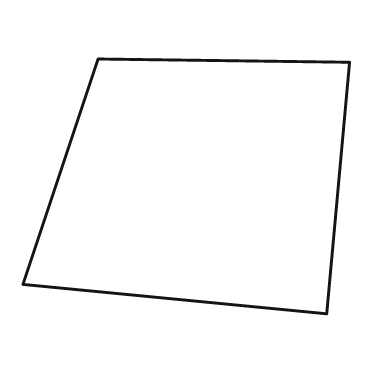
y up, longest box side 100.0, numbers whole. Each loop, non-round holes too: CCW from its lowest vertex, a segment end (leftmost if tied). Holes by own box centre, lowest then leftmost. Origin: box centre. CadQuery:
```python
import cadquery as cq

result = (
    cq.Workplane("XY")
    .moveTo(43.0, -39.0)
    .lineTo(50.0, 38.0)
    .lineTo(-27.0, 39.0)
    .lineTo(-50.0, -30.0)
    .close()
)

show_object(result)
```